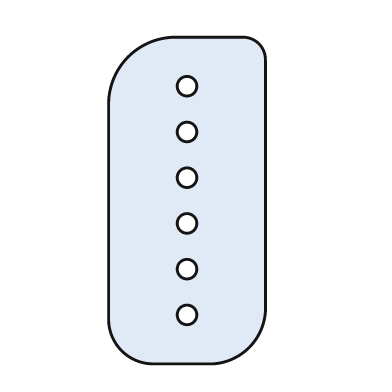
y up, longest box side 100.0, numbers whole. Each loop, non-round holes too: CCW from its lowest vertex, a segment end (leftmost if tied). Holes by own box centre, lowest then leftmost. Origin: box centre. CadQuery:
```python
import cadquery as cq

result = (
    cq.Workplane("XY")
    .moveTo(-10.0, -50.0)
    .lineTo(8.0, -50.0)
    .threePointArc((19.0, -45.0), (24.0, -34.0))
    .lineTo(24.0, 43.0)
    .threePointArc((22.0, 48.0), (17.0, 50.0))
    .lineTo(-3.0, 50.0)
    .threePointArc((-18.0, 44.0), (-24.0, 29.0))
    .lineTo(-24.0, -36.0)
    .threePointArc((-20.0, -46.0), (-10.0, -50.0))
    .close()
    .moveTo(0.0, -35.0)
    .circle(3.0)
    .moveTo(0.0, -21.0)
    .circle(3.0)
    .moveTo(0.0, -7.0)
    .circle(3.0)
    .moveTo(0.0, 7.0)
    .circle(3.0)
    .moveTo(0.0, 21.0)
    .circle(3.0)
    .moveTo(0.0, 35.0)
    .circle(3.0)
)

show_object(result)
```